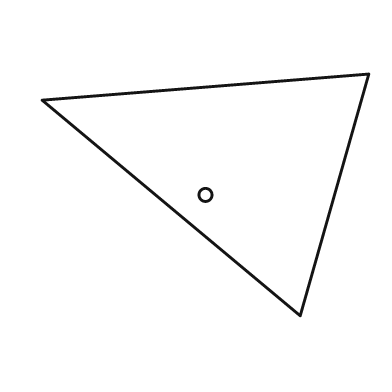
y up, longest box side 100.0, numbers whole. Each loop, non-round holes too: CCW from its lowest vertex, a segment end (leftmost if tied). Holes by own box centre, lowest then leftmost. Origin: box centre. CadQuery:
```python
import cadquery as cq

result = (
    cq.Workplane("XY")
    .moveTo(29.0, -37.0)
    .lineTo(50.0, 37.0)
    .lineTo(-50.0, 29.0)
    .close()
    .moveTo(0.0, 0.0)
    .circle(2.0)
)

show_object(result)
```